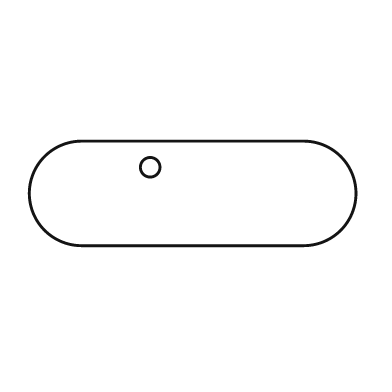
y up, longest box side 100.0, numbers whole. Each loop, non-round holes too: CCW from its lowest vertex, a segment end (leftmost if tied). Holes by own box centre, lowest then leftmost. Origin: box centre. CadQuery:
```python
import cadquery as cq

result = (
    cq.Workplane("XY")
    .moveTo(-34.0, -16.0)
    .lineTo(34.0, -16.0)
    .threePointArc((50.0, 0.0), (34.0, 16.0))
    .lineTo(-34.0, 16.0)
    .threePointArc((-50.0, 0.0), (-34.0, -16.0))
    .close()
    .moveTo(-13.0, 8.0)
    .circle(3.0)
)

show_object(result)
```